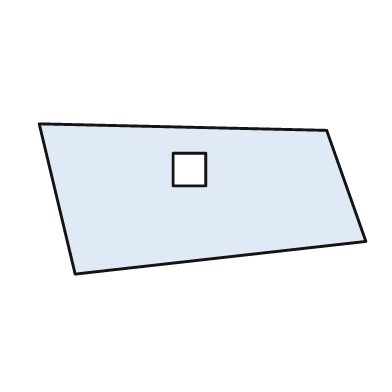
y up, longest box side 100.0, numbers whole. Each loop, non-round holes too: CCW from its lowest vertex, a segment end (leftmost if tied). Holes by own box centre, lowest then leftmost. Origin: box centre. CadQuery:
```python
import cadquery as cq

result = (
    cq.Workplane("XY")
    .moveTo(-39.0, -23.0)
    .lineTo(50.0, -13.0)
    .lineTo(38.0, 21.0)
    .lineTo(-50.0, 23.0)
    .close()
    .moveTo(-9.0, 4.0)
    .lineTo(1.0, 4.0)
    .lineTo(1.0, 14.0)
    .lineTo(-9.0, 14.0)
    .close()
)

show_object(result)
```